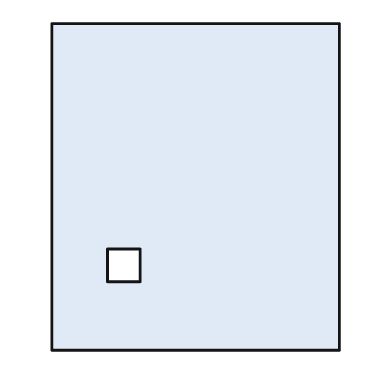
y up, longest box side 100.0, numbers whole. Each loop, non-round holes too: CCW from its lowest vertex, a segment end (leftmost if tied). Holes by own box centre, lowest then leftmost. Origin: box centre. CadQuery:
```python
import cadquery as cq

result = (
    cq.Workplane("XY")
    .moveTo(-44.0, -50.0)
    .lineTo(44.0, -50.0)
    .lineTo(44.0, 50.0)
    .lineTo(-44.0, 50.0)
    .close()
    .moveTo(-27.0, -29.0)
    .lineTo(-17.0, -29.0)
    .lineTo(-17.0, -19.0)
    .lineTo(-27.0, -19.0)
    .close()
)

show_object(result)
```